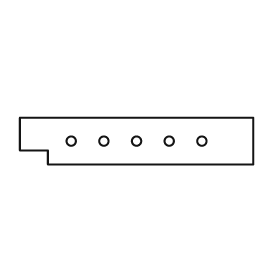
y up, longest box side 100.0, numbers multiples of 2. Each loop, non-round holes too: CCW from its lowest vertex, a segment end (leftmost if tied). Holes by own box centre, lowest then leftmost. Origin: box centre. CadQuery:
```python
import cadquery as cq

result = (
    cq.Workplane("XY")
    .moveTo(-38.0, -10.0)
    .lineTo(50.0, -10.0)
    .lineTo(50.0, 10.0)
    .lineTo(-50.0, 10.0)
    .lineTo(-50.0, -4.0)
    .lineTo(-38.0, -4.0)
    .close()
    .moveTo(-28.0, 0.0)
    .circle(2.0)
    .moveTo(-14.0, 0.0)
    .circle(2.0)
    .moveTo(0.0, 0.0)
    .circle(2.0)
    .moveTo(14.0, 0.0)
    .circle(2.0)
    .moveTo(28.0, 0.0)
    .circle(2.0)
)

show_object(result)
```